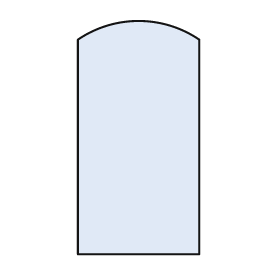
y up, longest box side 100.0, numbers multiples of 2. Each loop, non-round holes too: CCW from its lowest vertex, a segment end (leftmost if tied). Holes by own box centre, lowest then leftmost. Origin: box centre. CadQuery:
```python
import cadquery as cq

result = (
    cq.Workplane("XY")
    .moveTo(-26.0, -50.0)
    .lineTo(26.0, -50.0)
    .lineTo(26.0, 42.0)
    .threePointArc((0.0, 50.0), (-26.0, 42.0))
    .close()
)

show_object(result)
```